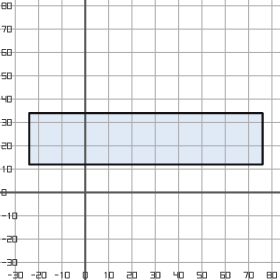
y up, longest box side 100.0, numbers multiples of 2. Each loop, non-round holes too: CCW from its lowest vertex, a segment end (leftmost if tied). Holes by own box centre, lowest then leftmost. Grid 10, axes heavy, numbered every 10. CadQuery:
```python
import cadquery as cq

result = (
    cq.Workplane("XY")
    .moveTo(-24.0, 12.0)
    .lineTo(76.0, 12.0)
    .lineTo(76.0, 34.0)
    .lineTo(-24.0, 34.0)
    .close()
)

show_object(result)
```